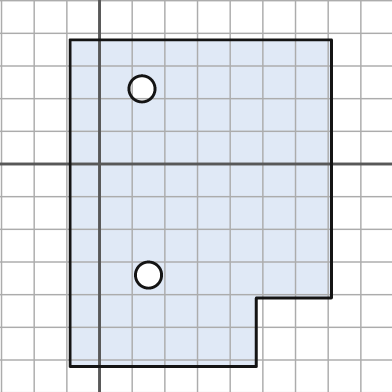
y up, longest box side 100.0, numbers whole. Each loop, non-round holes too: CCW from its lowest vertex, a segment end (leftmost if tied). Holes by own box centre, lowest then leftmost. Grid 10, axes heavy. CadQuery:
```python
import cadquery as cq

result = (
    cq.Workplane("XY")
    .moveTo(-9.0, -62.0)
    .lineTo(48.0, -62.0)
    .lineTo(48.0, -41.0)
    .lineTo(71.0, -41.0)
    .lineTo(71.0, 38.0)
    .lineTo(-9.0, 38.0)
    .close()
    .moveTo(15.0, -34.0)
    .circle(4.0)
    .moveTo(13.0, 23.0)
    .circle(4.0)
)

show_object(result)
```